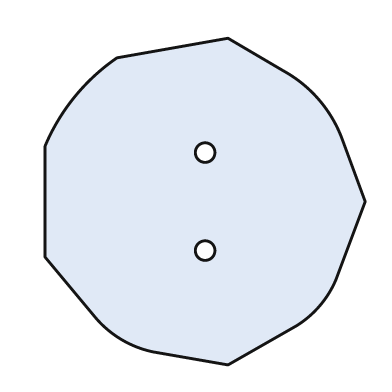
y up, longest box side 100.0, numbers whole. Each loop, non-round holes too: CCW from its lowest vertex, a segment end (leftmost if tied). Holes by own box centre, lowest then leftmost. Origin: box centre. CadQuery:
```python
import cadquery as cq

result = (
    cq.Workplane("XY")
    .moveTo(7.0, -50.0)
    .lineTo(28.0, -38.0)
    .threePointArc((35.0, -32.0), (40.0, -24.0))
    .lineTo(49.0, 0.0)
    .lineTo(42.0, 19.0)
    .threePointArc((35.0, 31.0), (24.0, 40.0))
    .lineTo(7.0, 50.0)
    .lineTo(-27.0, 44.0)
    .threePointArc((-40.0, 32.0), (-49.0, 17.0))
    .lineTo(-49.0, -17.0)
    .lineTo(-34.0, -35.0)
    .threePointArc((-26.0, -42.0), (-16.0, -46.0))
    .close()
    .moveTo(0.0, -15.0)
    .circle(3.0)
    .moveTo(0.0, 15.0)
    .circle(3.0)
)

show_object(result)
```